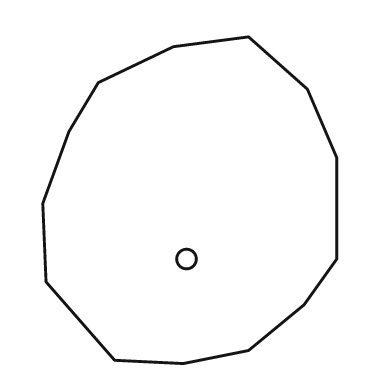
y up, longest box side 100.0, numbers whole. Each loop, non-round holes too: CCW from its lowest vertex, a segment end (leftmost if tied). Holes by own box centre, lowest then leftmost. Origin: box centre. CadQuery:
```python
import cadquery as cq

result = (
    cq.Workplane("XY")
    .moveTo(-2.0, -50.0)
    .lineTo(18.0, -46.0)
    .lineTo(35.0, -32.0)
    .lineTo(45.0, -18.0)
    .lineTo(45.0, 13.0)
    .lineTo(36.0, 34.0)
    .lineTo(18.0, 50.0)
    .lineTo(-5.0, 47.0)
    .lineTo(-28.0, 36.0)
    .lineTo(-37.0, 21.0)
    .lineTo(-45.0, -1.0)
    .lineTo(-44.0, -25.0)
    .lineTo(-23.0, -49.0)
    .close()
    .moveTo(-1.0, -18.0)
    .circle(3.0)
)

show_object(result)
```